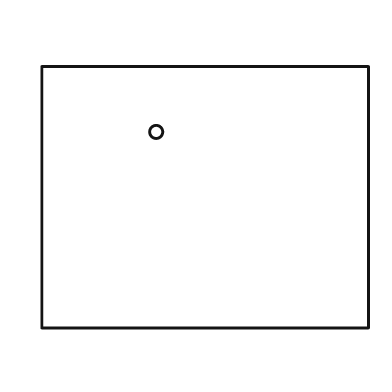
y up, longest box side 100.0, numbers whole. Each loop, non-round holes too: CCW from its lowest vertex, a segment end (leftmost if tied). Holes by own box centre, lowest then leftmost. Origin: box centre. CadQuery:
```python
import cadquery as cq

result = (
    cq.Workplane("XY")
    .moveTo(-50.0, -40.0)
    .lineTo(50.0, -40.0)
    .lineTo(50.0, 40.0)
    .lineTo(-50.0, 40.0)
    .close()
    .moveTo(-15.0, 20.0)
    .circle(2.0)
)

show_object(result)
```